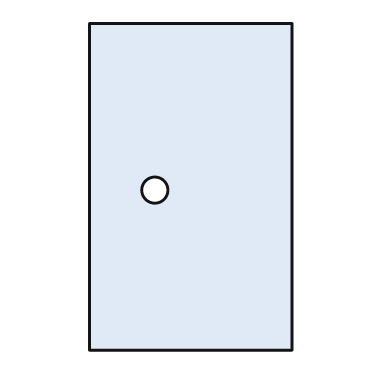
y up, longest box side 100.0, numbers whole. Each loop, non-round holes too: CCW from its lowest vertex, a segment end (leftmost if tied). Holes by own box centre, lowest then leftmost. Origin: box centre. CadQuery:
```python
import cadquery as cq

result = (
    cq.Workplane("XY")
    .moveTo(-31.0, -50.0)
    .lineTo(31.0, -50.0)
    .lineTo(31.0, 50.0)
    .lineTo(-31.0, 50.0)
    .close()
    .moveTo(-11.0, -1.0)
    .circle(4.0)
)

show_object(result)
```